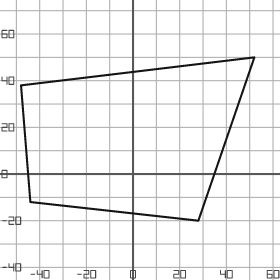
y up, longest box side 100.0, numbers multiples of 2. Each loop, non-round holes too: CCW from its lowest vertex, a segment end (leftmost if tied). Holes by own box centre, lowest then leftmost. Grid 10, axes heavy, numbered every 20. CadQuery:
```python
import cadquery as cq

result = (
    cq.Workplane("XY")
    .moveTo(28.0, -20.0)
    .lineTo(52.0, 50.0)
    .lineTo(-48.0, 38.0)
    .lineTo(-44.0, -12.0)
    .close()
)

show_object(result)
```